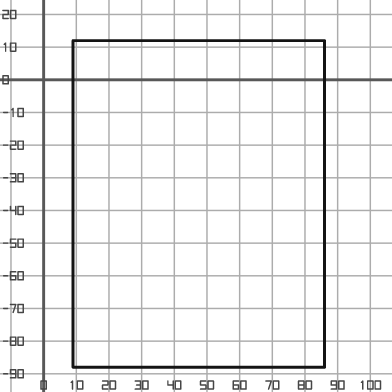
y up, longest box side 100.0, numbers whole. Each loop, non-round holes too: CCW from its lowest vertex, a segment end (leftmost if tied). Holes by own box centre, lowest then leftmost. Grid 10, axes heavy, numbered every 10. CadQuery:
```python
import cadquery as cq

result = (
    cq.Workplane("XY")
    .moveTo(9.0, -88.0)
    .lineTo(86.0, -88.0)
    .lineTo(86.0, 12.0)
    .lineTo(9.0, 12.0)
    .close()
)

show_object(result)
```